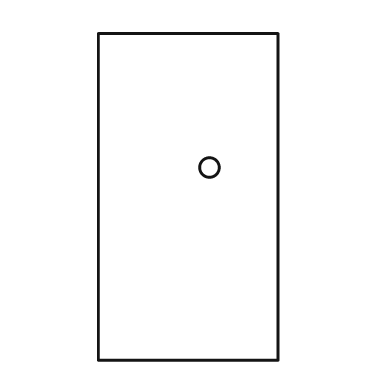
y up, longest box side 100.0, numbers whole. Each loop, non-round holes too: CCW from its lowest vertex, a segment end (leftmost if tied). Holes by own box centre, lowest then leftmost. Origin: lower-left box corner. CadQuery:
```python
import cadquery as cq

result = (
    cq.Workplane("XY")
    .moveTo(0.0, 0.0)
    .lineTo(55.0, 0.0)
    .lineTo(55.0, 100.0)
    .lineTo(0.0, 100.0)
    .close()
    .moveTo(34.0, 59.0)
    .circle(3.0)
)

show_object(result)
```